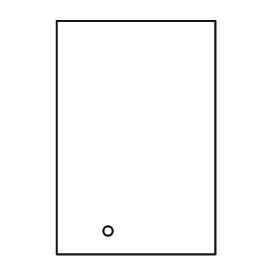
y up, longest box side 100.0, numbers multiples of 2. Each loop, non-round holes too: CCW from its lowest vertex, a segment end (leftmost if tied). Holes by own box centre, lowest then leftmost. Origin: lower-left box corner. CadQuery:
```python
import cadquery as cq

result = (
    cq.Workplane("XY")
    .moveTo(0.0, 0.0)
    .lineTo(68.0, 0.0)
    .lineTo(68.0, 100.0)
    .lineTo(0.0, 100.0)
    .close()
    .moveTo(22.0, 10.0)
    .circle(2.0)
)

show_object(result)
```